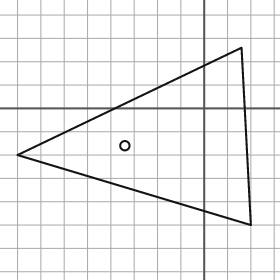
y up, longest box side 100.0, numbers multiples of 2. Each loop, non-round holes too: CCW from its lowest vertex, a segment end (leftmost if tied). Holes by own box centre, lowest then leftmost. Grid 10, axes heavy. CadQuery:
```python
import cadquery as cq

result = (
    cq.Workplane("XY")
    .moveTo(20.0, -50.0)
    .lineTo(16.0, 26.0)
    .lineTo(-80.0, -20.0)
    .close()
    .moveTo(-34.0, -16.0)
    .circle(2.0)
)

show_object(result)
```